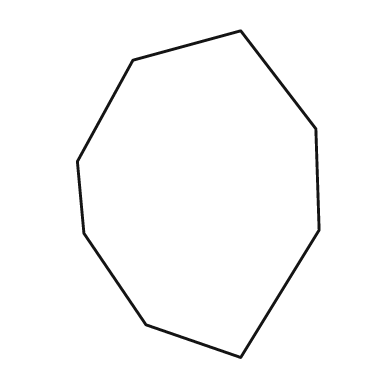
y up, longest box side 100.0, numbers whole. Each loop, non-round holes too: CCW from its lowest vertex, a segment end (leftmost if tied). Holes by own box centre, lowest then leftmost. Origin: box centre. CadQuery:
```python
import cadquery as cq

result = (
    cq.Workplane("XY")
    .moveTo(13.0, -50.0)
    .lineTo(37.0, -11.0)
    .lineTo(36.0, 20.0)
    .lineTo(13.0, 50.0)
    .lineTo(-20.0, 41.0)
    .lineTo(-37.0, 10.0)
    .lineTo(-35.0, -12.0)
    .lineTo(-16.0, -40.0)
    .close()
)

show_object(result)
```